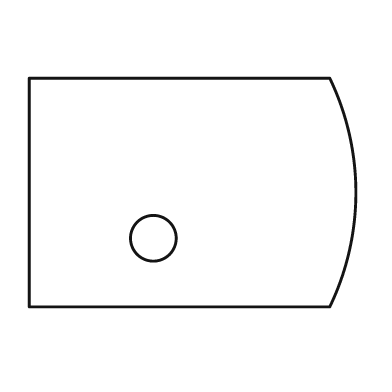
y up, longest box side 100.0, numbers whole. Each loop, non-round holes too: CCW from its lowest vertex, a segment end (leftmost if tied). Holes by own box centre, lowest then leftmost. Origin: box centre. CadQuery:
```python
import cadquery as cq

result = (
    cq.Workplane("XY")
    .moveTo(-50.0, -35.0)
    .lineTo(42.0, -35.0)
    .threePointArc((50.0, 0.0), (42.0, 35.0))
    .lineTo(-50.0, 35.0)
    .close()
    .moveTo(-12.0, -14.0)
    .circle(7.0)
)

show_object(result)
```